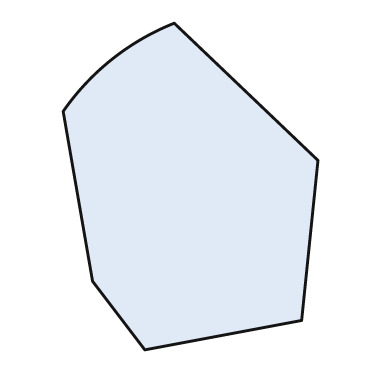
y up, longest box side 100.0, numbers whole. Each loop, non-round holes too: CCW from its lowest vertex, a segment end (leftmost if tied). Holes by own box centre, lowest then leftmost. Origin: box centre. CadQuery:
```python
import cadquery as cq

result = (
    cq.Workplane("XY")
    .moveTo(-14.0, -50.0)
    .lineTo(34.0, -41.0)
    .lineTo(39.0, 8.0)
    .lineTo(-5.0, 50.0)
    .threePointArc((-24.0, 39.0), (-39.0, 23.0))
    .lineTo(-30.0, -29.0)
    .close()
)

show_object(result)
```